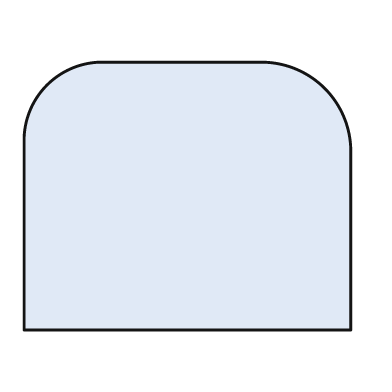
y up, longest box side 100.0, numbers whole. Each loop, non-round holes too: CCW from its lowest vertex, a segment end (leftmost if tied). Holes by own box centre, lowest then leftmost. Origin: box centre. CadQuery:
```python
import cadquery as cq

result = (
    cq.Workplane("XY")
    .moveTo(-50.0, -41.0)
    .lineTo(50.0, -41.0)
    .lineTo(50.0, 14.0)
    .threePointArc((42.0, 33.0), (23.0, 41.0))
    .lineTo(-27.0, 41.0)
    .threePointArc((-43.0, 34.0), (-50.0, 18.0))
    .close()
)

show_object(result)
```